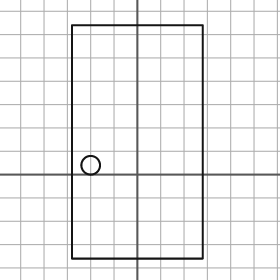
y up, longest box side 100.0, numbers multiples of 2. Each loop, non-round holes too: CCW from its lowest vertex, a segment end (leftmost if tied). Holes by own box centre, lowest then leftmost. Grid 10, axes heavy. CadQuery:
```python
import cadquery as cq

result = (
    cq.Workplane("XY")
    .moveTo(-28.0, -36.0)
    .lineTo(28.0, -36.0)
    .lineTo(28.0, 64.0)
    .lineTo(-28.0, 64.0)
    .close()
    .moveTo(-20.0, 4.0)
    .circle(4.0)
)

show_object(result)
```